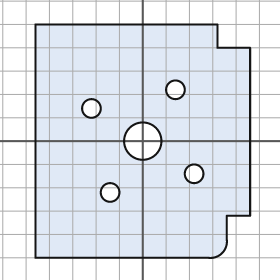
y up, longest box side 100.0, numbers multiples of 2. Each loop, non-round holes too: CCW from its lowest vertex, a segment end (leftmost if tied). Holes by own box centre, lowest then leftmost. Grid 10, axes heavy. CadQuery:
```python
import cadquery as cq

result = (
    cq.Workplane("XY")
    .moveTo(-46.0, -50.0)
    .lineTo(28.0, -50.0)
    .threePointArc((34.0, -48.0), (36.0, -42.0))
    .lineTo(36.0, -32.0)
    .lineTo(46.0, -32.0)
    .lineTo(46.0, 40.0)
    .lineTo(32.0, 40.0)
    .lineTo(32.0, 50.0)
    .lineTo(-46.0, 50.0)
    .close()
    .moveTo(-14.0, -22.0)
    .circle(4.0)
    .moveTo(22.0, -14.0)
    .circle(4.0)
    .moveTo(0.0, 0.0)
    .circle(8.0)
    .moveTo(-22.0, 14.0)
    .circle(4.0)
    .moveTo(14.0, 22.0)
    .circle(4.0)
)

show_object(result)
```